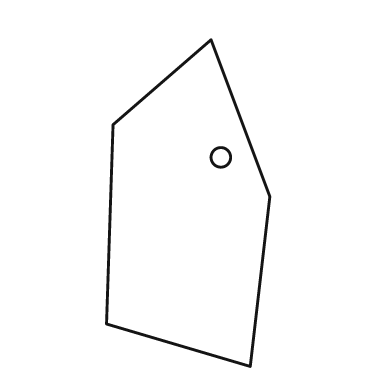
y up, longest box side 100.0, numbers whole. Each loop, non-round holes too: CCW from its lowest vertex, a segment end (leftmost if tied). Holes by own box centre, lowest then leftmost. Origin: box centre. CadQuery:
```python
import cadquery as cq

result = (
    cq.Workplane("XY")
    .moveTo(19.0, -50.0)
    .lineTo(25.0, 2.0)
    .lineTo(7.0, 50.0)
    .lineTo(-23.0, 24.0)
    .lineTo(-25.0, -37.0)
    .close()
    .moveTo(10.0, 14.0)
    .circle(3.0)
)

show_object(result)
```